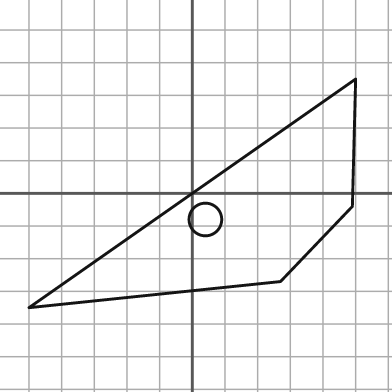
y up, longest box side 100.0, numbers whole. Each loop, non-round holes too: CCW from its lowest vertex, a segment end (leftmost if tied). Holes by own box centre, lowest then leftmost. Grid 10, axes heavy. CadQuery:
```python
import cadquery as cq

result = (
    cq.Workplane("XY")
    .moveTo(-50.0, -35.0)
    .lineTo(27.0, -27.0)
    .lineTo(49.0, -4.0)
    .lineTo(50.0, 35.0)
    .close()
    .moveTo(4.0, -8.0)
    .circle(5.0)
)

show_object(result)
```